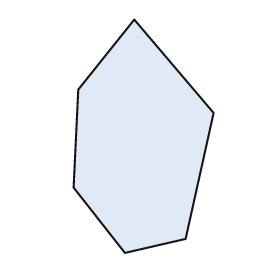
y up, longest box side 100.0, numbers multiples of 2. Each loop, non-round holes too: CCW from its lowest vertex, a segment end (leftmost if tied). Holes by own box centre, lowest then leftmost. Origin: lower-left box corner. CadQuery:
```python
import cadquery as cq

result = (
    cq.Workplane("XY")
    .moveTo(22.0, 0.0)
    .lineTo(48.0, 6.0)
    .lineTo(60.0, 60.0)
    .lineTo(26.0, 100.0)
    .lineTo(2.0, 70.0)
    .lineTo(0.0, 28.0)
    .close()
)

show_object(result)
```